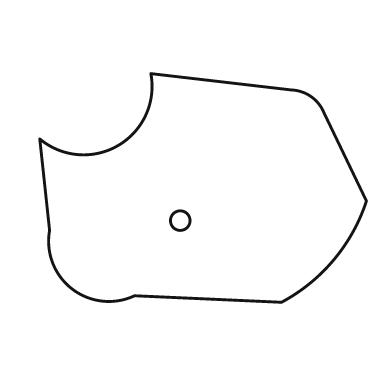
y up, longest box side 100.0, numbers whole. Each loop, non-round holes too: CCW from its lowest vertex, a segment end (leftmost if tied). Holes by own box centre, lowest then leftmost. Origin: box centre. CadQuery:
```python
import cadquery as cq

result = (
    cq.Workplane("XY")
    .moveTo(24.0, -35.0)
    .threePointArc((40.0, -22.0), (50.0, -4.0))
    .lineTo(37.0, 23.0)
    .threePointArc((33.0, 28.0), (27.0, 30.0))
    .lineTo(-16.0, 35.0)
    .threePointArc((-26.0, 13.0), (-50.0, 15.0))
    .lineTo(-47.0, -13.0)
    .threePointArc((-40.0, -31.0), (-21.0, -33.0))
    .close()
    .moveTo(-7.0, -10.0)
    .circle(3.0)
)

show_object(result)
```